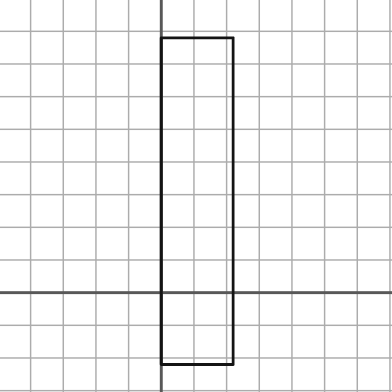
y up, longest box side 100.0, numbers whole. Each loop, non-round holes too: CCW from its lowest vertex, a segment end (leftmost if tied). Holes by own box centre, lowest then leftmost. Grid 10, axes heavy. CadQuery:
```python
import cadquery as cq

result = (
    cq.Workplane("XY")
    .moveTo(0.0, -22.0)
    .lineTo(22.0, -22.0)
    .lineTo(22.0, 78.0)
    .lineTo(0.0, 78.0)
    .close()
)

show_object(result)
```